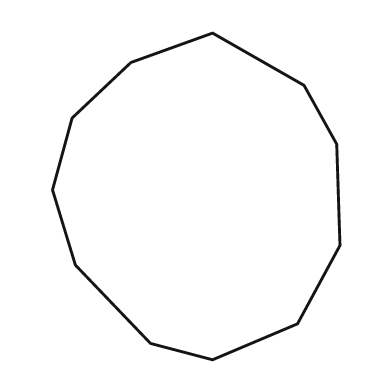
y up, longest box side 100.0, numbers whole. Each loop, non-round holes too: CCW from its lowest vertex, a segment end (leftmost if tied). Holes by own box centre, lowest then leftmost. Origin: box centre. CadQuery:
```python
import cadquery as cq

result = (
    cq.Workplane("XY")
    .moveTo(5.0, -50.0)
    .lineTo(31.0, -39.0)
    .lineTo(44.0, -15.0)
    .lineTo(43.0, 16.0)
    .lineTo(33.0, 34.0)
    .lineTo(5.0, 50.0)
    .lineTo(-20.0, 41.0)
    .lineTo(-38.0, 24.0)
    .lineTo(-44.0, 2.0)
    .lineTo(-37.0, -21.0)
    .lineTo(-14.0, -45.0)
    .close()
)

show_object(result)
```